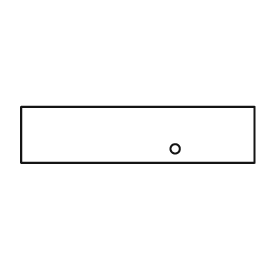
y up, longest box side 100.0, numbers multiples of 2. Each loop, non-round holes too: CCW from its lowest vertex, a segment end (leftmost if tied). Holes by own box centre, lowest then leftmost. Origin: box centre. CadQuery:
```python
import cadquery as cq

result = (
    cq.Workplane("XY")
    .moveTo(-50.0, -12.0)
    .lineTo(50.0, -12.0)
    .lineTo(50.0, 12.0)
    .lineTo(-50.0, 12.0)
    .close()
    .moveTo(16.0, -6.0)
    .circle(2.0)
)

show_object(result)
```